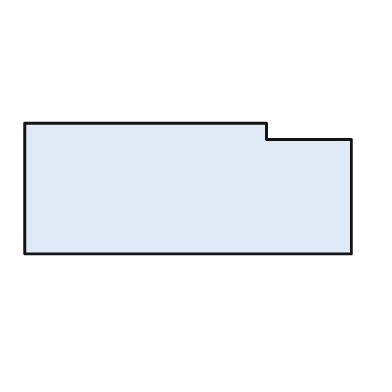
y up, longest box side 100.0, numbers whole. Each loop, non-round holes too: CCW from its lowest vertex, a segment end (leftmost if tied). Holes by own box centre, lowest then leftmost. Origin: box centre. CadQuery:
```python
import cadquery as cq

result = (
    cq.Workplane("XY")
    .moveTo(-50.0, -20.0)
    .lineTo(50.0, -20.0)
    .lineTo(50.0, 15.0)
    .lineTo(24.0, 15.0)
    .lineTo(24.0, 20.0)
    .lineTo(-50.0, 20.0)
    .close()
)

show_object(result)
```